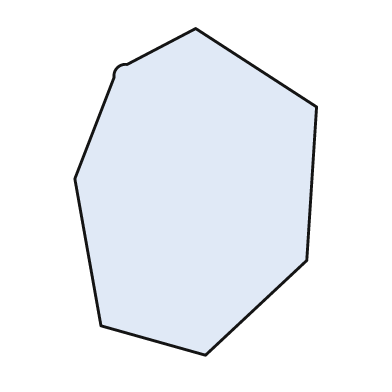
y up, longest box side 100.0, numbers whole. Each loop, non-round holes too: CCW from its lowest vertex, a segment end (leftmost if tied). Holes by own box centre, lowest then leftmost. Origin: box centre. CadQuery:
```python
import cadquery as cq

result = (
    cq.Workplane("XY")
    .moveTo(3.0, -50.0)
    .lineTo(34.0, -21.0)
    .lineTo(37.0, 26.0)
    .lineTo(0.0, 50.0)
    .lineTo(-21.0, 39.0)
    .threePointArc((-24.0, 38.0), (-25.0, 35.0))
    .lineTo(-37.0, 4.0)
    .lineTo(-29.0, -41.0)
    .close()
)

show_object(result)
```